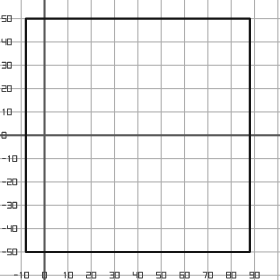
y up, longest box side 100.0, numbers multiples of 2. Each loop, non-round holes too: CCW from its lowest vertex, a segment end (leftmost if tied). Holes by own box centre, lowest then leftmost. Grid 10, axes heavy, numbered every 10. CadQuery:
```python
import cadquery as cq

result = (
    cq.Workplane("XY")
    .moveTo(-8.0, -50.0)
    .lineTo(88.0, -50.0)
    .lineTo(88.0, 50.0)
    .lineTo(-8.0, 50.0)
    .close()
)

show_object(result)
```